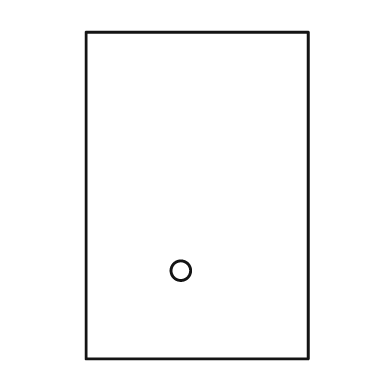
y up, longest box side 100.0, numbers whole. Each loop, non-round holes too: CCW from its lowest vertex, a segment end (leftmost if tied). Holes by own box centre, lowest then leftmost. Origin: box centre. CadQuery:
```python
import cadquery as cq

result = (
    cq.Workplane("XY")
    .moveTo(-34.0, -50.0)
    .lineTo(34.0, -50.0)
    .lineTo(34.0, 50.0)
    .lineTo(-34.0, 50.0)
    .close()
    .moveTo(-5.0, -23.0)
    .circle(3.0)
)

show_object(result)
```